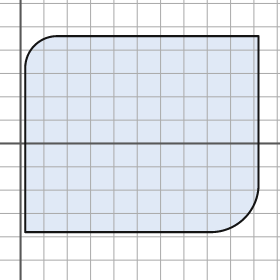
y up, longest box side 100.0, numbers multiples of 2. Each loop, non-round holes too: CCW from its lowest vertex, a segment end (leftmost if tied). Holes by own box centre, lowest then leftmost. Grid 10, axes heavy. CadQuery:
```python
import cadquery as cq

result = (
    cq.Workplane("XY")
    .moveTo(2.0, -38.0)
    .lineTo(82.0, -38.0)
    .threePointArc((96.0, -32.0), (102.0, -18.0))
    .lineTo(102.0, 46.0)
    .lineTo(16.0, 46.0)
    .threePointArc((6.0, 42.0), (2.0, 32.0))
    .close()
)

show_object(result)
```